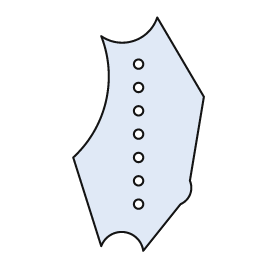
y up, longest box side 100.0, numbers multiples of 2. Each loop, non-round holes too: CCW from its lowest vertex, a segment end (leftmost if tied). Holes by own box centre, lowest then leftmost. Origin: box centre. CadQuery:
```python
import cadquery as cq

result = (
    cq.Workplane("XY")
    .moveTo(2.0, -50.0)
    .lineTo(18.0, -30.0)
    .threePointArc((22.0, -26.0), (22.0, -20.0))
    .lineTo(28.0, 16.0)
    .lineTo(8.0, 50.0)
    .threePointArc((-2.0, 40.0), (-16.0, 42.0))
    .threePointArc((-14.0, 14.0), (-28.0, -10.0))
    .lineTo(-16.0, -48.0)
    .threePointArc((-6.0, -42.0), (2.0, -50.0))
    .close()
    .moveTo(0.0, -30.0)
    .circle(2.0)
    .moveTo(0.0, -20.0)
    .circle(2.0)
    .moveTo(0.0, -10.0)
    .circle(2.0)
    .moveTo(0.0, 0.0)
    .circle(2.0)
    .moveTo(0.0, 10.0)
    .circle(2.0)
    .moveTo(0.0, 20.0)
    .circle(2.0)
    .moveTo(0.0, 30.0)
    .circle(2.0)
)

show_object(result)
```